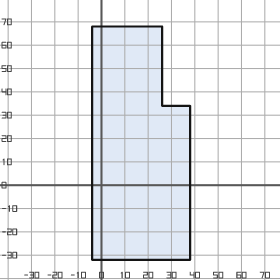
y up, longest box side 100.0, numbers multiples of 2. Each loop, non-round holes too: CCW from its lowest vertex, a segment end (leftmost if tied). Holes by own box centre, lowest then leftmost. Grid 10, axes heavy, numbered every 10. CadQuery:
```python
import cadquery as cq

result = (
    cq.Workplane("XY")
    .moveTo(-4.0, -32.0)
    .lineTo(38.0, -32.0)
    .lineTo(38.0, 34.0)
    .lineTo(26.0, 34.0)
    .lineTo(26.0, 68.0)
    .lineTo(-4.0, 68.0)
    .close()
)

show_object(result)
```